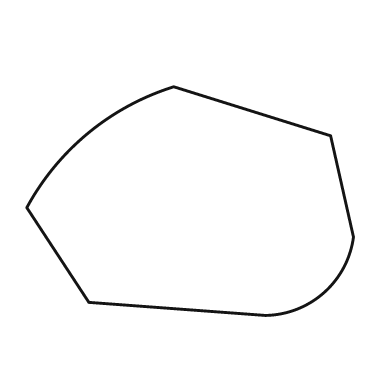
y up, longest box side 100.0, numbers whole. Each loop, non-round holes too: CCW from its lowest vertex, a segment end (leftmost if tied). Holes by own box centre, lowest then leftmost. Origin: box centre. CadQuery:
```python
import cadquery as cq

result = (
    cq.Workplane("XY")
    .moveTo(23.0, -35.0)
    .threePointArc((41.0, -28.0), (50.0, -11.0))
    .lineTo(43.0, 20.0)
    .lineTo(-5.0, 35.0)
    .threePointArc((-31.0, 21.0), (-50.0, -2.0))
    .lineTo(-31.0, -31.0)
    .close()
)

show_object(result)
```